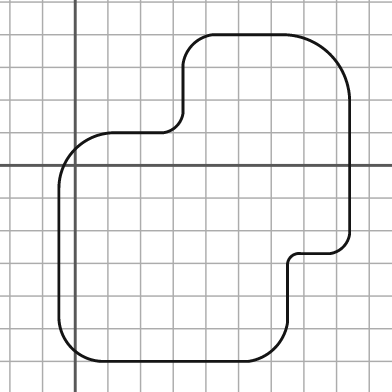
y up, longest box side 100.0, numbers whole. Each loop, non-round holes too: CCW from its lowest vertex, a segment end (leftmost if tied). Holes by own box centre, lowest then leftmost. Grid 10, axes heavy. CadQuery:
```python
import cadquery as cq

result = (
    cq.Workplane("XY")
    .moveTo(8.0, -60.0)
    .lineTo(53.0, -60.0)
    .threePointArc((61.0, -56.0), (65.0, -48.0))
    .lineTo(65.0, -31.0)
    .threePointArc((66.0, -28.0), (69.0, -27.0))
    .lineTo(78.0, -27.0)
    .threePointArc((82.0, -25.0), (84.0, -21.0))
    .lineTo(84.0, 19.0)
    .threePointArc((78.0, 34.0), (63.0, 40.0))
    .lineTo(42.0, 40.0)
    .threePointArc((36.0, 37.0), (33.0, 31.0))
    .lineTo(33.0, 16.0)
    .threePointArc((31.0, 12.0), (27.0, 10.0))
    .lineTo(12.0, 10.0)
    .threePointArc((0.0, 5.0), (-5.0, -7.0))
    .lineTo(-5.0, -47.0)
    .threePointArc((-1.0, -56.0), (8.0, -60.0))
    .close()
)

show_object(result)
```